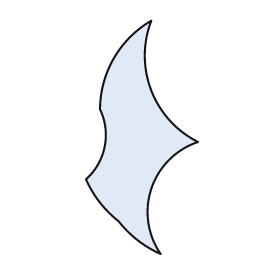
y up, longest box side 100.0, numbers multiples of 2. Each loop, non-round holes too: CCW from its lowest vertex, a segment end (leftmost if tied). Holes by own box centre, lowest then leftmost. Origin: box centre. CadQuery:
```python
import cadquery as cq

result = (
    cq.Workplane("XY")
    .moveTo(8.0, -50.0)
    .threePointArc((4.0, -22.0), (24.0, -2.0))
    .threePointArc((4.0, 20.0), (4.0, 50.0))
    .threePointArc((-12.0, 34.0), (-18.0, 12.0))
    .threePointArc((-16.0, -4.0), (-24.0, -18.0))
    .threePointArc((-18.0, -28.0), (-10.0, -36.0))
    .threePointArc((-2.0, -44.0), (8.0, -50.0))
    .close()
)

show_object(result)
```